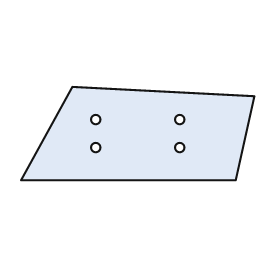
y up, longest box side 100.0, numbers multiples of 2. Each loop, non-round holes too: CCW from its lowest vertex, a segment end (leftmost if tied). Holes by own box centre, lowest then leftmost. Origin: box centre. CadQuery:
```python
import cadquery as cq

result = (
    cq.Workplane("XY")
    .moveTo(-50.0, -20.0)
    .lineTo(42.0, -20.0)
    .lineTo(50.0, 16.0)
    .lineTo(-28.0, 20.0)
    .close()
    .moveTo(-18.0, -6.0)
    .circle(2.0)
    .moveTo(18.0, -6.0)
    .circle(2.0)
    .moveTo(-18.0, 6.0)
    .circle(2.0)
    .moveTo(18.0, 6.0)
    .circle(2.0)
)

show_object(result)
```